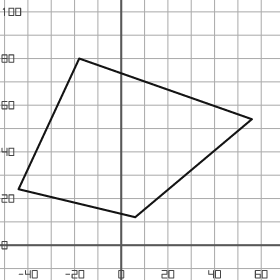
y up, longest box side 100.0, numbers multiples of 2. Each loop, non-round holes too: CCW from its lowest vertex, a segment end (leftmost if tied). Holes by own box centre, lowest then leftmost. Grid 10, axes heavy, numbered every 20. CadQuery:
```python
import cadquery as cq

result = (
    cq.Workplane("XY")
    .moveTo(6.0, 12.0)
    .lineTo(56.0, 54.0)
    .lineTo(-18.0, 80.0)
    .lineTo(-44.0, 24.0)
    .close()
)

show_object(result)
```